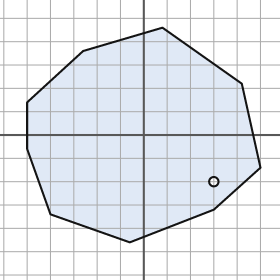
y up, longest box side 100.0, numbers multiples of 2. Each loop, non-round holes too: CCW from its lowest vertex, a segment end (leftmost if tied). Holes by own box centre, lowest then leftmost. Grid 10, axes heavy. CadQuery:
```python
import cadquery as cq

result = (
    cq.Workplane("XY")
    .moveTo(-6.0, -46.0)
    .lineTo(30.0, -32.0)
    .lineTo(50.0, -14.0)
    .lineTo(42.0, 22.0)
    .lineTo(8.0, 46.0)
    .lineTo(-26.0, 36.0)
    .lineTo(-50.0, 14.0)
    .lineTo(-50.0, -6.0)
    .lineTo(-40.0, -34.0)
    .close()
    .moveTo(30.0, -20.0)
    .circle(2.0)
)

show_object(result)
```